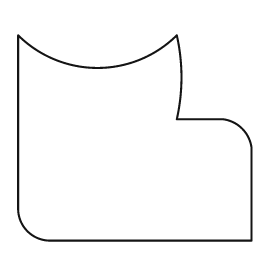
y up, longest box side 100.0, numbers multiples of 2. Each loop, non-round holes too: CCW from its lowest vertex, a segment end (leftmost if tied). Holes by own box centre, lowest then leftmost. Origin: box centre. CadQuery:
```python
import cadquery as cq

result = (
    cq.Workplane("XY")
    .moveTo(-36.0, -44.0)
    .lineTo(50.0, -44.0)
    .lineTo(50.0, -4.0)
    .threePointArc((46.0, 4.0), (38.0, 8.0))
    .lineTo(18.0, 8.0)
    .threePointArc((20.0, 26.0), (18.0, 44.0))
    .threePointArc((-16.0, 30.0), (-50.0, 44.0))
    .lineTo(-50.0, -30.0)
    .threePointArc((-46.0, -40.0), (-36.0, -44.0))
    .close()
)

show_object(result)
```